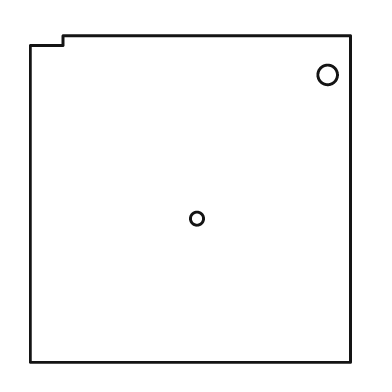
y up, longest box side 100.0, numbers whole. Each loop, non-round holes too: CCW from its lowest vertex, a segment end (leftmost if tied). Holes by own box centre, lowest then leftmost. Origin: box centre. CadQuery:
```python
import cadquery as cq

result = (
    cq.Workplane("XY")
    .moveTo(-49.0, -50.0)
    .lineTo(49.0, -50.0)
    .lineTo(49.0, 50.0)
    .lineTo(-39.0, 50.0)
    .lineTo(-39.0, 47.0)
    .lineTo(-49.0, 47.0)
    .close()
    .moveTo(2.0, -6.0)
    .circle(2.0)
    .moveTo(42.0, 38.0)
    .circle(3.0)
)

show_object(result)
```